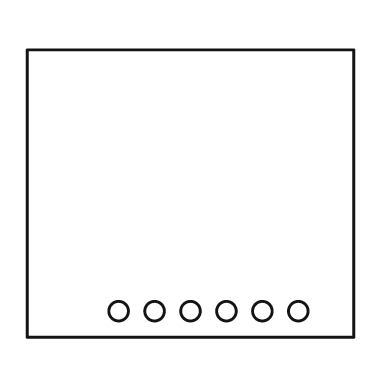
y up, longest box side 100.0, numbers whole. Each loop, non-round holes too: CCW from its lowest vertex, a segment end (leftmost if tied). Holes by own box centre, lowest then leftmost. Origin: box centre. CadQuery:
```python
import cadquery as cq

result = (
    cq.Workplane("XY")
    .moveTo(-50.0, -44.0)
    .lineTo(50.0, -44.0)
    .lineTo(50.0, 44.0)
    .lineTo(-50.0, 44.0)
    .close()
    .moveTo(-22.0, -36.0)
    .circle(3.0)
    .moveTo(-11.0, -36.0)
    .circle(3.0)
    .moveTo(0.0, -36.0)
    .circle(3.0)
    .moveTo(11.0, -36.0)
    .circle(3.0)
    .moveTo(22.0, -36.0)
    .circle(3.0)
    .moveTo(33.0, -36.0)
    .circle(3.0)
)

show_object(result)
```